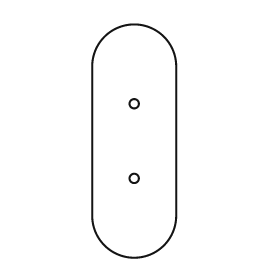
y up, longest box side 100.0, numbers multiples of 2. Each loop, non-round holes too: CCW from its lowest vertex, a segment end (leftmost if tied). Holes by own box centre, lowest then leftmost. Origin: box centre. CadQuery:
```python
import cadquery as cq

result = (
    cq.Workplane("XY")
    .moveTo(-18.0, -32.0)
    .threePointArc((0.0, -50.0), (18.0, -32.0))
    .lineTo(18.0, 32.0)
    .threePointArc((0.0, 50.0), (-18.0, 32.0))
    .close()
    .moveTo(0.0, -16.0)
    .circle(2.0)
    .moveTo(0.0, 16.0)
    .circle(2.0)
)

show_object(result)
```